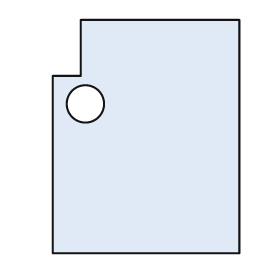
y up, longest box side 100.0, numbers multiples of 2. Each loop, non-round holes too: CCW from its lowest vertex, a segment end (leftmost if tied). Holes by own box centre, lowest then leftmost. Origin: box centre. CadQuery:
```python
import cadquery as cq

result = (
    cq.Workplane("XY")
    .moveTo(-40.0, -50.0)
    .lineTo(40.0, -50.0)
    .lineTo(40.0, 50.0)
    .lineTo(-28.0, 50.0)
    .lineTo(-28.0, 26.0)
    .lineTo(-40.0, 26.0)
    .close()
    .moveTo(-26.0, 14.0)
    .circle(8.0)
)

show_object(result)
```